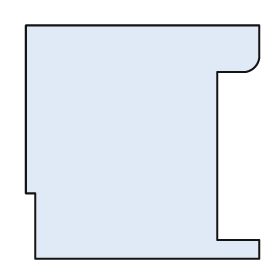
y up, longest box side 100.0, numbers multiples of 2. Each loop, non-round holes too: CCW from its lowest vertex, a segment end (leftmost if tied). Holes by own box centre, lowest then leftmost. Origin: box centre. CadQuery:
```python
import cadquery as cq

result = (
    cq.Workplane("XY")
    .moveTo(-46.0, -50.0)
    .lineTo(50.0, -50.0)
    .lineTo(50.0, -42.0)
    .lineTo(32.0, -42.0)
    .lineTo(32.0, 30.0)
    .lineTo(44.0, 30.0)
    .threePointArc((48.0, 32.0), (50.0, 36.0))
    .lineTo(50.0, 50.0)
    .lineTo(-50.0, 50.0)
    .lineTo(-50.0, -22.0)
    .lineTo(-46.0, -22.0)
    .close()
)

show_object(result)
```